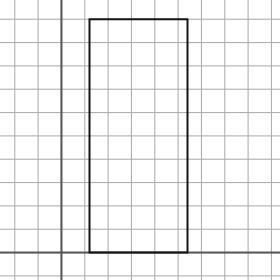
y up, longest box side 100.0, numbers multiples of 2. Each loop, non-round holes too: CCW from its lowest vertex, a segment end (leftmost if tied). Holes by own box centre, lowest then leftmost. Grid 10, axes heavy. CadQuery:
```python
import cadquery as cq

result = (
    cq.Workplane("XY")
    .moveTo(12.0, 0.0)
    .lineTo(54.0, 0.0)
    .lineTo(54.0, 100.0)
    .lineTo(12.0, 100.0)
    .close()
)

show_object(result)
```